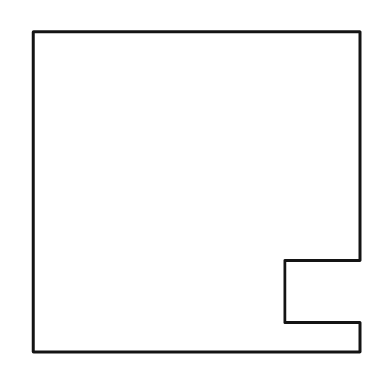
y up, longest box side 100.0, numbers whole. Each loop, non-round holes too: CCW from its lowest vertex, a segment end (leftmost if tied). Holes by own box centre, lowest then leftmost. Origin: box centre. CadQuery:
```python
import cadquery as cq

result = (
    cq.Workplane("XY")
    .moveTo(-50.0, -49.0)
    .lineTo(50.0, -49.0)
    .lineTo(50.0, -40.0)
    .lineTo(27.0, -40.0)
    .lineTo(27.0, -21.0)
    .lineTo(50.0, -21.0)
    .lineTo(50.0, 49.0)
    .lineTo(-50.0, 49.0)
    .close()
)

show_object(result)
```